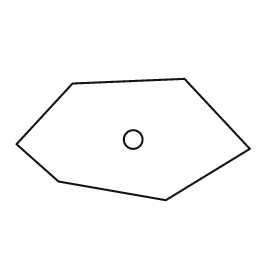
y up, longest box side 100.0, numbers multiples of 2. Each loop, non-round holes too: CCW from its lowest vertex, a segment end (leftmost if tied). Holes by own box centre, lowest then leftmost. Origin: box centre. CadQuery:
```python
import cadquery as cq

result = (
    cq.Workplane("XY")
    .moveTo(14.0, -26.0)
    .lineTo(50.0, -4.0)
    .lineTo(22.0, 26.0)
    .lineTo(-26.0, 24.0)
    .lineTo(-50.0, -2.0)
    .lineTo(-32.0, -18.0)
    .close()
    .moveTo(0.0, 0.0)
    .circle(4.0)
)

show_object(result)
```